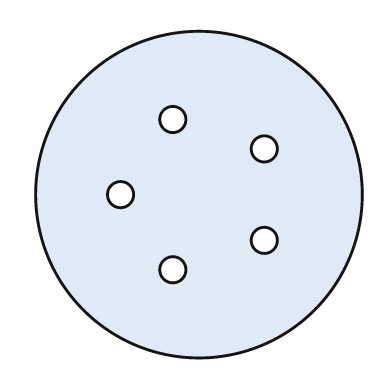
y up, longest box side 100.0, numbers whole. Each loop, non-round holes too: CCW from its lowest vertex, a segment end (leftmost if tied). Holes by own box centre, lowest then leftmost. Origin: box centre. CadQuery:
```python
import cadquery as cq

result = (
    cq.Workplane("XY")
    .moveTo(0.0, 0.0)
    .circle(50.0)
    .moveTo(-8.0, -23.0)
    .circle(4.0)
    .moveTo(20.0, -14.0)
    .circle(4.0)
    .moveTo(-24.0, 0.0)
    .circle(4.0)
    .moveTo(20.0, 14.0)
    .circle(4.0)
    .moveTo(-8.0, 23.0)
    .circle(4.0)
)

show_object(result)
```